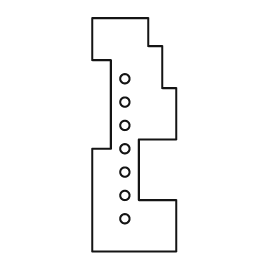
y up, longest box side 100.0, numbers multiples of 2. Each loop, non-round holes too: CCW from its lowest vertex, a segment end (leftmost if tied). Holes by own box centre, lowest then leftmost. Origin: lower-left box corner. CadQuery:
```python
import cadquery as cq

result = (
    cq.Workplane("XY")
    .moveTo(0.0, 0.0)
    .lineTo(36.0, 0.0)
    .lineTo(36.0, 22.0)
    .lineTo(20.0, 22.0)
    .lineTo(20.0, 48.0)
    .lineTo(36.0, 48.0)
    .lineTo(36.0, 70.0)
    .lineTo(30.0, 70.0)
    .lineTo(30.0, 88.0)
    .lineTo(24.0, 88.0)
    .lineTo(24.0, 100.0)
    .lineTo(0.0, 100.0)
    .lineTo(0.0, 82.0)
    .lineTo(8.0, 82.0)
    .lineTo(8.0, 44.0)
    .lineTo(0.0, 44.0)
    .close()
    .moveTo(14.0, 14.0)
    .circle(2.0)
    .moveTo(14.0, 24.0)
    .circle(2.0)
    .moveTo(14.0, 34.0)
    .circle(2.0)
    .moveTo(14.0, 44.0)
    .circle(2.0)
    .moveTo(14.0, 54.0)
    .circle(2.0)
    .moveTo(14.0, 64.0)
    .circle(2.0)
    .moveTo(14.0, 74.0)
    .circle(2.0)
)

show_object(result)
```